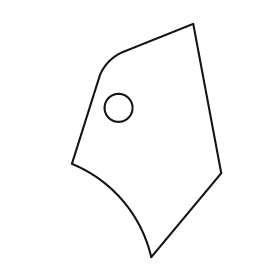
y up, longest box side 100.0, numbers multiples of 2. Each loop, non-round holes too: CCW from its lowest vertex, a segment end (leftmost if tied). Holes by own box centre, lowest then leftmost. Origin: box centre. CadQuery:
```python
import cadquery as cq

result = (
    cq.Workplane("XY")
    .moveTo(2.0, -50.0)
    .lineTo(32.0, -14.0)
    .lineTo(20.0, 50.0)
    .lineTo(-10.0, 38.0)
    .threePointArc((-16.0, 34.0), (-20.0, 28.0))
    .lineTo(-32.0, -10.0)
    .threePointArc((-10.0, -26.0), (2.0, -50.0))
    .close()
    .moveTo(-12.0, 14.0)
    .circle(6.0)
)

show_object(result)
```